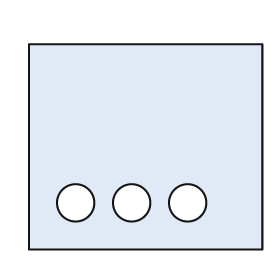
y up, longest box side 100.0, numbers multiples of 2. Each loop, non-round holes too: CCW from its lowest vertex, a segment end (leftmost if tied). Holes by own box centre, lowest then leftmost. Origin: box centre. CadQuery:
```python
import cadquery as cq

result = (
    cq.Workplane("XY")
    .moveTo(-50.0, -44.0)
    .lineTo(50.0, -44.0)
    .lineTo(50.0, 44.0)
    .lineTo(-50.0, 44.0)
    .close()
    .moveTo(-30.0, -24.0)
    .circle(8.0)
    .moveTo(-6.0, -24.0)
    .circle(8.0)
    .moveTo(18.0, -24.0)
    .circle(8.0)
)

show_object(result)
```